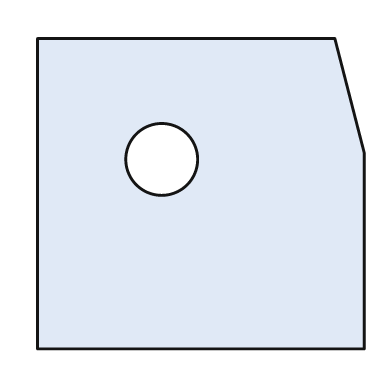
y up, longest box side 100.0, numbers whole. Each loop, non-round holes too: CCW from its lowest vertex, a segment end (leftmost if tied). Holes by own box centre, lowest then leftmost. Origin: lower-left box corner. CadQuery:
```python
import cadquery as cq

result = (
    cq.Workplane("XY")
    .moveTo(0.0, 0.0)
    .lineTo(100.0, 0.0)
    .lineTo(100.0, 60.0)
    .lineTo(91.0, 95.0)
    .lineTo(0.0, 95.0)
    .close()
    .moveTo(38.0, 58.0)
    .circle(11.0)
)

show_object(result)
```